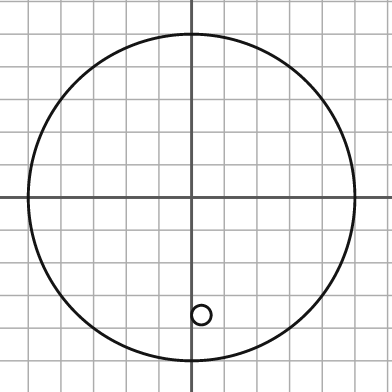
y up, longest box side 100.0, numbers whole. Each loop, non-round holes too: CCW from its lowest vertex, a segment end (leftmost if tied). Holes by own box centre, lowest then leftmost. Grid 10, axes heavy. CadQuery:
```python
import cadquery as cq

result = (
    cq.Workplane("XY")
    .moveTo(0.0, 0.0)
    .circle(50.0)
    .moveTo(3.0, -36.0)
    .circle(3.0)
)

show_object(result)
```